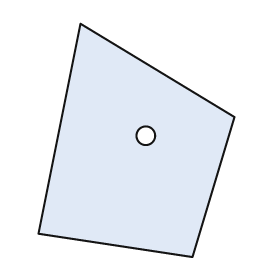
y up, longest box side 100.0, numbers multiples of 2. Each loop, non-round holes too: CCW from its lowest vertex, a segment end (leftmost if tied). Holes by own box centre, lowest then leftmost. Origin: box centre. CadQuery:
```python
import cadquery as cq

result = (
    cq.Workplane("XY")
    .moveTo(24.0, -50.0)
    .lineTo(42.0, 10.0)
    .lineTo(-24.0, 50.0)
    .lineTo(-42.0, -40.0)
    .close()
    .moveTo(4.0, 2.0)
    .circle(4.0)
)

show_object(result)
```